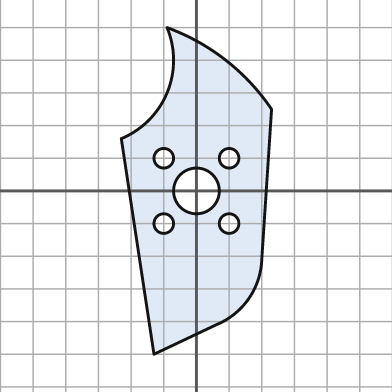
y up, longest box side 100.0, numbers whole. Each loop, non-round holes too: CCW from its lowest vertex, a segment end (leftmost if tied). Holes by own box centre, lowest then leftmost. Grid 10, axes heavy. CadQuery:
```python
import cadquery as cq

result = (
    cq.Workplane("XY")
    .moveTo(-13.0, -50.0)
    .lineTo(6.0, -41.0)
    .threePointArc((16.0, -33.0), (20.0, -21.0))
    .lineTo(23.0, 25.0)
    .threePointArc((9.0, 40.0), (-9.0, 50.0))
    .threePointArc((-9.0, 30.0), (-23.0, 16.0))
    .close()
    .moveTo(-10.0, -10.0)
    .circle(3.0)
    .moveTo(10.0, -10.0)
    .circle(3.0)
    .moveTo(0.0, 0.0)
    .circle(7.0)
    .moveTo(-10.0, 10.0)
    .circle(3.0)
    .moveTo(10.0, 10.0)
    .circle(3.0)
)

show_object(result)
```